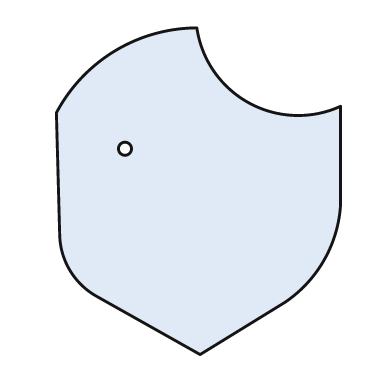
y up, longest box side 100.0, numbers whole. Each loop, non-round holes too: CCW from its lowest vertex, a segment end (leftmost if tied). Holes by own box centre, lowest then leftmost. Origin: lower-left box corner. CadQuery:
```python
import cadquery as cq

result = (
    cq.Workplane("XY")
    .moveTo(44.0, 0.0)
    .lineTo(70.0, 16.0)
    .threePointArc((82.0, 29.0), (87.0, 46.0))
    .lineTo(87.0, 76.0)
    .threePointArc((59.0, 77.0), (43.0, 100.0))
    .threePointArc((18.0, 93.0), (0.0, 74.0))
    .lineTo(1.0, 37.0)
    .threePointArc((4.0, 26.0), (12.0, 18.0))
    .close()
    .moveTo(21.0, 63.0)
    .circle(2.0)
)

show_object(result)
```